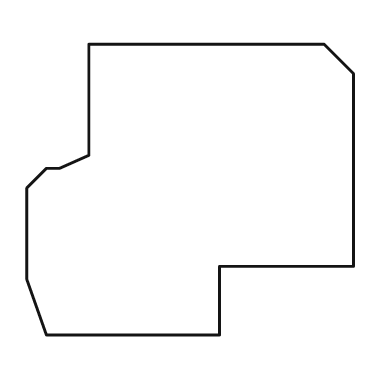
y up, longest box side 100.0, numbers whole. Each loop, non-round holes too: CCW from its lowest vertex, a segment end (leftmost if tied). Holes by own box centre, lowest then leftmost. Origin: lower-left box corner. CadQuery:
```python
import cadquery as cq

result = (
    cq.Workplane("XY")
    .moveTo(6.0, 0.0)
    .lineTo(59.0, 0.0)
    .lineTo(59.0, 21.0)
    .lineTo(100.0, 21.0)
    .lineTo(100.0, 80.0)
    .lineTo(91.0, 89.0)
    .lineTo(19.0, 89.0)
    .lineTo(19.0, 55.0)
    .lineTo(10.0, 51.0)
    .lineTo(6.0, 51.0)
    .lineTo(0.0, 45.0)
    .lineTo(0.0, 17.0)
    .close()
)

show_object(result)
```